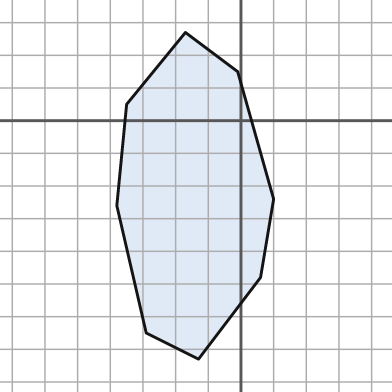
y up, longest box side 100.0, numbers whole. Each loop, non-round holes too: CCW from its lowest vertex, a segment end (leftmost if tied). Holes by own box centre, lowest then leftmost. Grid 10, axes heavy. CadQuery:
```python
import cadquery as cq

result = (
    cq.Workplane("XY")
    .moveTo(-13.0, -73.0)
    .lineTo(6.0, -48.0)
    .lineTo(10.0, -24.0)
    .lineTo(-1.0, 15.0)
    .lineTo(-17.0, 27.0)
    .lineTo(-35.0, 5.0)
    .lineTo(-38.0, -26.0)
    .lineTo(-29.0, -65.0)
    .close()
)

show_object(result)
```